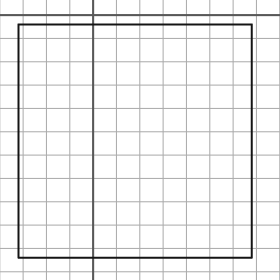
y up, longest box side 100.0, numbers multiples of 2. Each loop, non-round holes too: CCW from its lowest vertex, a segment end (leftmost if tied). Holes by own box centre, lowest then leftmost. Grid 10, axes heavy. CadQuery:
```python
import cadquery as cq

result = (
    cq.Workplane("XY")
    .moveTo(-32.0, -104.0)
    .lineTo(68.0, -104.0)
    .lineTo(68.0, -4.0)
    .lineTo(-32.0, -4.0)
    .close()
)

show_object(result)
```